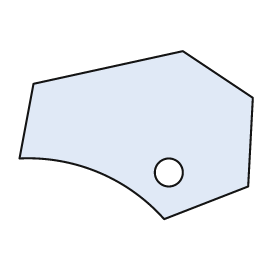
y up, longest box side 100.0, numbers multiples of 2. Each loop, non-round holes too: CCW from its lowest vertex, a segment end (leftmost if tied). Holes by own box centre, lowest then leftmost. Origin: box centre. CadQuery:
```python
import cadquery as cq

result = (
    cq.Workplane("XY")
    .moveTo(12.0, -36.0)
    .lineTo(48.0, -22.0)
    .lineTo(50.0, 16.0)
    .lineTo(20.0, 36.0)
    .lineTo(-44.0, 22.0)
    .lineTo(-50.0, -10.0)
    .threePointArc((-16.0, -16.0), (12.0, -36.0))
    .close()
    .moveTo(14.0, -16.0)
    .circle(6.0)
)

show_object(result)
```